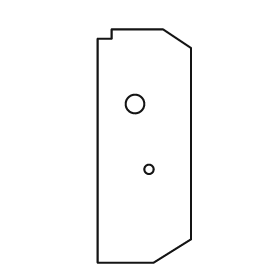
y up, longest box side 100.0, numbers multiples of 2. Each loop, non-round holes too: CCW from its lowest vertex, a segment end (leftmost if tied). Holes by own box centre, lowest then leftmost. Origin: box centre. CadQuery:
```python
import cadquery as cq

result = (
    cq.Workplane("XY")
    .moveTo(-20.0, -50.0)
    .lineTo(4.0, -50.0)
    .lineTo(20.0, -40.0)
    .lineTo(20.0, 42.0)
    .lineTo(8.0, 50.0)
    .lineTo(-14.0, 50.0)
    .lineTo(-14.0, 46.0)
    .lineTo(-20.0, 46.0)
    .close()
    .moveTo(2.0, -10.0)
    .circle(2.0)
    .moveTo(-4.0, 18.0)
    .circle(4.0)
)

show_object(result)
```